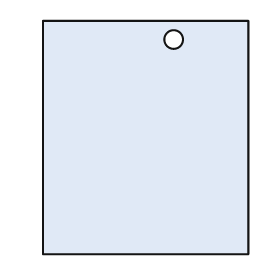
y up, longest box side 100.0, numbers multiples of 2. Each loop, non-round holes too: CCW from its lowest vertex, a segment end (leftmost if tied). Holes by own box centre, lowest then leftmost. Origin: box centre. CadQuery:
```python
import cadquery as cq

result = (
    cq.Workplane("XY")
    .moveTo(-44.0, -50.0)
    .lineTo(44.0, -50.0)
    .lineTo(44.0, 50.0)
    .lineTo(-44.0, 50.0)
    .close()
    .moveTo(12.0, 42.0)
    .circle(4.0)
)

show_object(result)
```